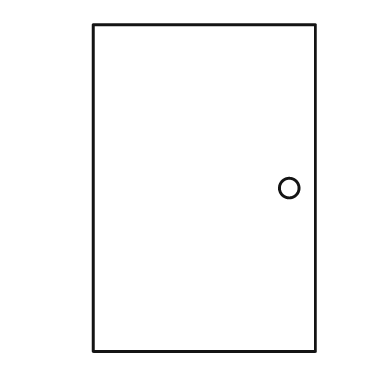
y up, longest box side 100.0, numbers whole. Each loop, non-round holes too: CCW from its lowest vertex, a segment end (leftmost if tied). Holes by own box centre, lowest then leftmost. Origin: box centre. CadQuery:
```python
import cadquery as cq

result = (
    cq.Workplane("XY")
    .moveTo(-34.0, -50.0)
    .lineTo(34.0, -50.0)
    .lineTo(34.0, 50.0)
    .lineTo(-34.0, 50.0)
    .close()
    .moveTo(26.0, 0.0)
    .circle(3.0)
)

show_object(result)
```